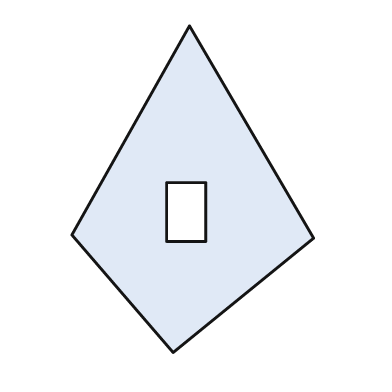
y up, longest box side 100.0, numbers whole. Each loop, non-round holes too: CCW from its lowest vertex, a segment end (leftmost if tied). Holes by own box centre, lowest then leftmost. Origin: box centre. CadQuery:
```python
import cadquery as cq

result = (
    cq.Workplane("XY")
    .moveTo(-6.0, -50.0)
    .lineTo(37.0, -15.0)
    .lineTo(-1.0, 50.0)
    .lineTo(-37.0, -14.0)
    .close()
    .moveTo(-8.0, -16.0)
    .lineTo(4.0, -16.0)
    .lineTo(4.0, 2.0)
    .lineTo(-8.0, 2.0)
    .close()
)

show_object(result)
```